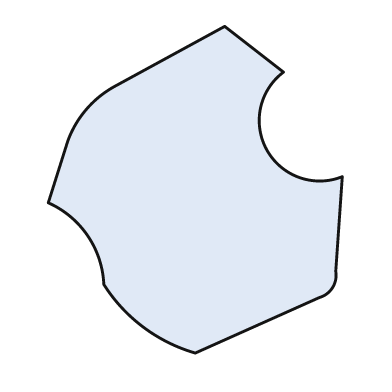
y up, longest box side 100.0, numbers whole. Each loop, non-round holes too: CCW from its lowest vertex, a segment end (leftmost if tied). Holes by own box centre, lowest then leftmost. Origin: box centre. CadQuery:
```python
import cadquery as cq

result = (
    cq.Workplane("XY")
    .moveTo(0.0, -50.0)
    .lineTo(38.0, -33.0)
    .threePointArc((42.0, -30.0), (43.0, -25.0))
    .lineTo(45.0, 4.0)
    .threePointArc((22.0, 12.0), (27.0, 36.0))
    .lineTo(9.0, 50.0)
    .lineTo(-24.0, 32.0)
    .threePointArc((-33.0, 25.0), (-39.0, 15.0))
    .lineTo(-45.0, -4.0)
    .threePointArc((-33.0, -14.0), (-28.0, -29.0))
    .threePointArc((-16.0, -42.0), (0.0, -50.0))
    .close()
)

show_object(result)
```